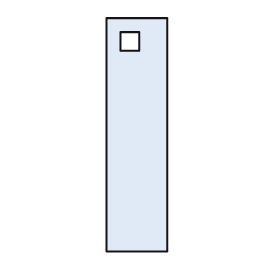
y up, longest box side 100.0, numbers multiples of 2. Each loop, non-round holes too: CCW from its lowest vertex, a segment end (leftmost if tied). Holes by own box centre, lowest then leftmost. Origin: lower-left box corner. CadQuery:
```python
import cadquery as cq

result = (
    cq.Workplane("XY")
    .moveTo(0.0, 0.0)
    .lineTo(26.0, 0.0)
    .lineTo(26.0, 100.0)
    .lineTo(0.0, 100.0)
    .close()
    .moveTo(6.0, 86.0)
    .lineTo(14.0, 86.0)
    .lineTo(14.0, 94.0)
    .lineTo(6.0, 94.0)
    .close()
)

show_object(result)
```